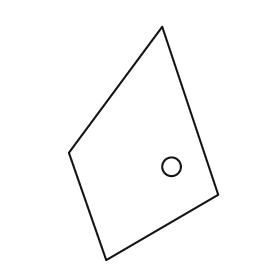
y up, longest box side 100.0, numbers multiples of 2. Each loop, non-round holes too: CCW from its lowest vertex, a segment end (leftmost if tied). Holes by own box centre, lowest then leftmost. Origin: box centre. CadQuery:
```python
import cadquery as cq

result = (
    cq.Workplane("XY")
    .moveTo(-16.0, -50.0)
    .lineTo(32.0, -22.0)
    .lineTo(8.0, 50.0)
    .lineTo(-32.0, -4.0)
    .close()
    .moveTo(12.0, -10.0)
    .circle(4.0)
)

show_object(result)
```